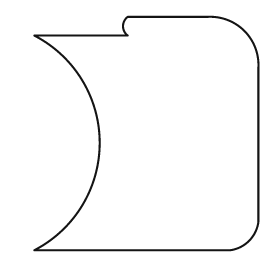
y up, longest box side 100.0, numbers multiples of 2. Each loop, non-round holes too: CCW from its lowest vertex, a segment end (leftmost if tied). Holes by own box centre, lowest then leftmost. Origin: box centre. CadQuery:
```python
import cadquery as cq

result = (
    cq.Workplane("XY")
    .moveTo(-48.0, -50.0)
    .lineTo(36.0, -50.0)
    .threePointArc((44.0, -46.0), (48.0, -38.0))
    .lineTo(48.0, 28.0)
    .threePointArc((42.0, 44.0), (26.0, 50.0))
    .lineTo(-8.0, 50.0)
    .threePointArc((-10.0, 46.0), (-8.0, 42.0))
    .lineTo(-48.0, 42.0)
    .threePointArc((-20.0, -4.0), (-48.0, -50.0))
    .close()
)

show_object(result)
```